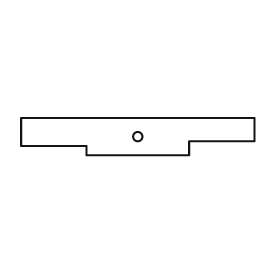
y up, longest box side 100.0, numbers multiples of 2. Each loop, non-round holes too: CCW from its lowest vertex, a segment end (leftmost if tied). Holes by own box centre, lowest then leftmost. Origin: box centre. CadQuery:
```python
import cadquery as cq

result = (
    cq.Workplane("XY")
    .moveTo(-22.0, -8.0)
    .lineTo(22.0, -8.0)
    .lineTo(22.0, -2.0)
    .lineTo(50.0, -2.0)
    .lineTo(50.0, 8.0)
    .lineTo(-50.0, 8.0)
    .lineTo(-50.0, -4.0)
    .lineTo(-22.0, -4.0)
    .close()
    .moveTo(0.0, 0.0)
    .circle(2.0)
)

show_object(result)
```